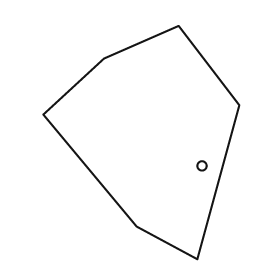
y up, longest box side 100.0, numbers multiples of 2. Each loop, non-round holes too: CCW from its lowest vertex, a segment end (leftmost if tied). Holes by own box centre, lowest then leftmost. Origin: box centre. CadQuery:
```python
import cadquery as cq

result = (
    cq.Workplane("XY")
    .moveTo(24.0, -50.0)
    .lineTo(42.0, 16.0)
    .lineTo(16.0, 50.0)
    .lineTo(-16.0, 36.0)
    .lineTo(-42.0, 12.0)
    .lineTo(-2.0, -36.0)
    .close()
    .moveTo(26.0, -10.0)
    .circle(2.0)
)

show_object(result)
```